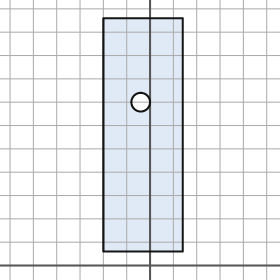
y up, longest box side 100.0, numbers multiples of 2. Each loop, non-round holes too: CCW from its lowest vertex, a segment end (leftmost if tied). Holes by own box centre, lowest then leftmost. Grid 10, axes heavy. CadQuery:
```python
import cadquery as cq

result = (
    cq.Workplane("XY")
    .moveTo(-20.0, 6.0)
    .lineTo(14.0, 6.0)
    .lineTo(14.0, 106.0)
    .lineTo(-20.0, 106.0)
    .close()
    .moveTo(-4.0, 70.0)
    .circle(4.0)
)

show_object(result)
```